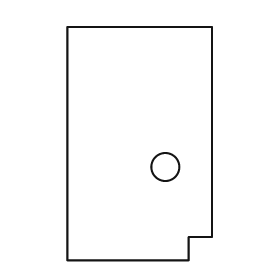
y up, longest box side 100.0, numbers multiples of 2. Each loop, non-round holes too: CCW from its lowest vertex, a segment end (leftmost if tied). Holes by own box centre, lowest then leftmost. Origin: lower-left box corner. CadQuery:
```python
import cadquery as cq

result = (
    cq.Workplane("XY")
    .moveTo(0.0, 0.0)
    .lineTo(52.0, 0.0)
    .lineTo(52.0, 10.0)
    .lineTo(62.0, 10.0)
    .lineTo(62.0, 100.0)
    .lineTo(0.0, 100.0)
    .close()
    .moveTo(42.0, 40.0)
    .circle(6.0)
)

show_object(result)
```